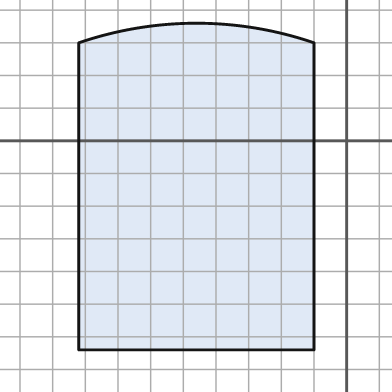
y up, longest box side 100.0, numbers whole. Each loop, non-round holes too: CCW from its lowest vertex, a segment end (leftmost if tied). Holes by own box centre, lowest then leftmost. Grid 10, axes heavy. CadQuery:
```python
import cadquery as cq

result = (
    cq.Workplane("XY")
    .moveTo(-82.0, -64.0)
    .lineTo(-10.0, -64.0)
    .lineTo(-10.0, 30.0)
    .threePointArc((-46.0, 36.0), (-82.0, 30.0))
    .close()
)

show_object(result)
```